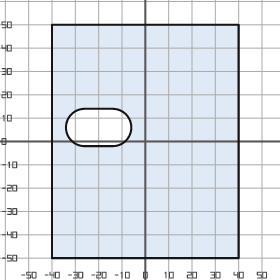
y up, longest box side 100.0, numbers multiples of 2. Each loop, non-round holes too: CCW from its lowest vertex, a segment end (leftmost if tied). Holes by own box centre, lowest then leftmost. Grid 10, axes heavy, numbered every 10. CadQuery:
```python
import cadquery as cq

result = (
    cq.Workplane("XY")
    .moveTo(-40.0, -50.0)
    .lineTo(40.0, -50.0)
    .lineTo(40.0, 50.0)
    .lineTo(-40.0, 50.0)
    .close()
    .moveTo(-26.0, -2.0)
    .lineTo(-14.0, -2.0)
    .threePointArc((-6.0, 6.0), (-14.0, 14.0))
    .lineTo(-26.0, 14.0)
    .threePointArc((-34.0, 6.0), (-26.0, -2.0))
    .close()
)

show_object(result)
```